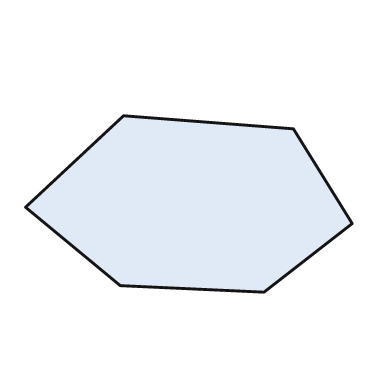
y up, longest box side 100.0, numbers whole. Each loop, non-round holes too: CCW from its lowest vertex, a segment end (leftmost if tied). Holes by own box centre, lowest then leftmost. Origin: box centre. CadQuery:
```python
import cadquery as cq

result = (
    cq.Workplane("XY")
    .moveTo(23.0, -27.0)
    .lineTo(50.0, -6.0)
    .lineTo(32.0, 23.0)
    .lineTo(-20.0, 27.0)
    .lineTo(-50.0, -1.0)
    .lineTo(-21.0, -25.0)
    .close()
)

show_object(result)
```